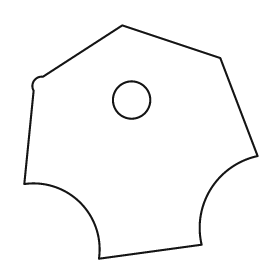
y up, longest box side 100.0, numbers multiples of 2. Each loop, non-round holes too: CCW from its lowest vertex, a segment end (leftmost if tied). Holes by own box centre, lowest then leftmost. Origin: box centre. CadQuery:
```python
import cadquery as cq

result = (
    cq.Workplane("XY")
    .moveTo(-18.0, -50.0)
    .lineTo(26.0, -44.0)
    .threePointArc((30.0, -20.0), (50.0, -6.0))
    .lineTo(34.0, 36.0)
    .lineTo(-8.0, 50.0)
    .lineTo(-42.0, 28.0)
    .threePointArc((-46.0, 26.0), (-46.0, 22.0))
    .lineTo(-50.0, -18.0)
    .threePointArc((-26.0, -26.0), (-18.0, -50.0))
    .close()
    .moveTo(-4.0, 18.0)
    .circle(8.0)
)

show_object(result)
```